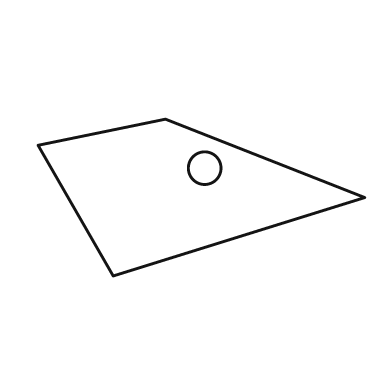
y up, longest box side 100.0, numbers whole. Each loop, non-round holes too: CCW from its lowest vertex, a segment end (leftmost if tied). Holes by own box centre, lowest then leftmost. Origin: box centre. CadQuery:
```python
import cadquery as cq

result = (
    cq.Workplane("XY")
    .moveTo(-27.0, -24.0)
    .lineTo(50.0, 0.0)
    .lineTo(-11.0, 24.0)
    .lineTo(-50.0, 16.0)
    .close()
    .moveTo(1.0, 9.0)
    .circle(5.0)
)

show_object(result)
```